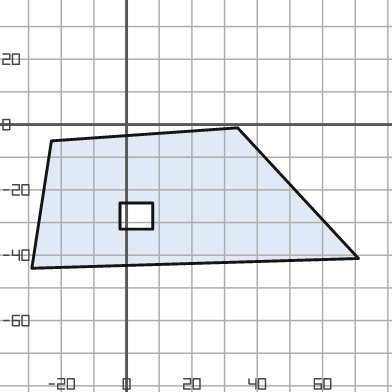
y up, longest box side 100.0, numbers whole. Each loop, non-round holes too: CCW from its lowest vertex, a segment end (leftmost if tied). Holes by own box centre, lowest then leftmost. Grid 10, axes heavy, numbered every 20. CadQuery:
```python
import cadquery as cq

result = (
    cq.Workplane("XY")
    .moveTo(-29.0, -44.0)
    .lineTo(71.0, -41.0)
    .lineTo(34.0, -1.0)
    .lineTo(-23.0, -5.0)
    .close()
    .moveTo(-2.0, -32.0)
    .lineTo(8.0, -32.0)
    .lineTo(8.0, -24.0)
    .lineTo(-2.0, -24.0)
    .close()
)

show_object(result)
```